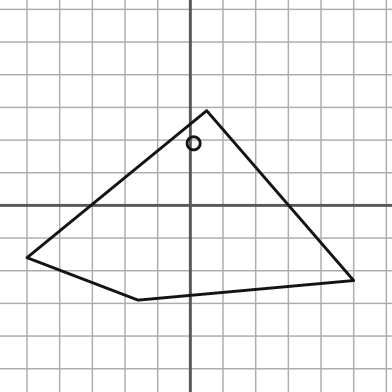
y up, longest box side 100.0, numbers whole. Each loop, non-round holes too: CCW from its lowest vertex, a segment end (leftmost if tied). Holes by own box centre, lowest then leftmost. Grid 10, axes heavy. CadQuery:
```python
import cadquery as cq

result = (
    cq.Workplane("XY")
    .moveTo(-16.0, -29.0)
    .lineTo(50.0, -23.0)
    .lineTo(5.0, 29.0)
    .lineTo(-50.0, -16.0)
    .close()
    .moveTo(1.0, 19.0)
    .circle(2.0)
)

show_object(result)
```